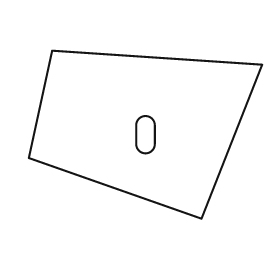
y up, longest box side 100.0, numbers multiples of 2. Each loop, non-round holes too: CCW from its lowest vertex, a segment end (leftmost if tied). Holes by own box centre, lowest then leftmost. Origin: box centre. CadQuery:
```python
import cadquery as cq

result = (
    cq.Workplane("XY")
    .moveTo(24.0, -36.0)
    .lineTo(50.0, 30.0)
    .lineTo(-40.0, 36.0)
    .lineTo(-50.0, -10.0)
    .close()
    .moveTo(-4.0, -4.0)
    .threePointArc((0.0, -8.0), (4.0, -4.0))
    .lineTo(4.0, 4.0)
    .threePointArc((0.0, 8.0), (-4.0, 4.0))
    .close()
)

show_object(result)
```